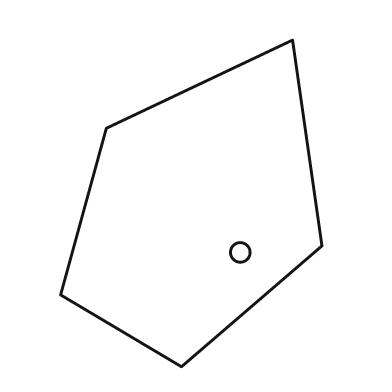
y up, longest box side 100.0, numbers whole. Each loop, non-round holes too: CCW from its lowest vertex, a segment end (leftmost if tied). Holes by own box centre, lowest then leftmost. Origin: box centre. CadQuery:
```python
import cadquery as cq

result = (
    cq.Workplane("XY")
    .moveTo(-3.0, -50.0)
    .lineTo(40.0, -13.0)
    .lineTo(31.0, 50.0)
    .lineTo(-26.0, 23.0)
    .lineTo(-40.0, -28.0)
    .close()
    .moveTo(15.0, -15.0)
    .circle(3.0)
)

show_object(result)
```